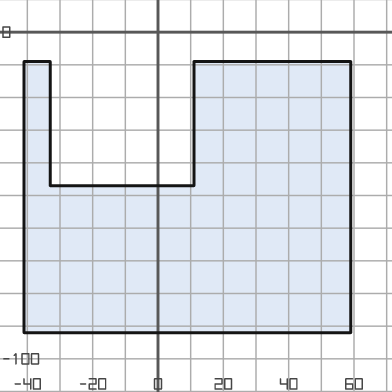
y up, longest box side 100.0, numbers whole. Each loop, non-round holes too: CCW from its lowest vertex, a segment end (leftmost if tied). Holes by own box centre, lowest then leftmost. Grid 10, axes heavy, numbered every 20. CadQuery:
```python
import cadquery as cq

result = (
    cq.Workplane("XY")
    .moveTo(-41.0, -92.0)
    .lineTo(59.0, -92.0)
    .lineTo(59.0, -9.0)
    .lineTo(11.0, -9.0)
    .lineTo(11.0, -47.0)
    .lineTo(-33.0, -47.0)
    .lineTo(-33.0, -9.0)
    .lineTo(-41.0, -9.0)
    .close()
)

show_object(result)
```